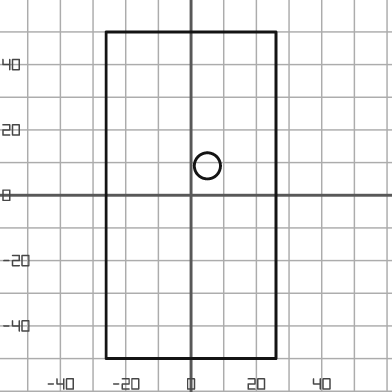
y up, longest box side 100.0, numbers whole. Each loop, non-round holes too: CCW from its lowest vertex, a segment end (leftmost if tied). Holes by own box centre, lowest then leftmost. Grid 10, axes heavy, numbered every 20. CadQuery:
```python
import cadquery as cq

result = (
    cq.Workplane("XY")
    .moveTo(-26.0, -50.0)
    .lineTo(26.0, -50.0)
    .lineTo(26.0, 50.0)
    .lineTo(-26.0, 50.0)
    .close()
    .moveTo(5.0, 9.0)
    .circle(4.0)
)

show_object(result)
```